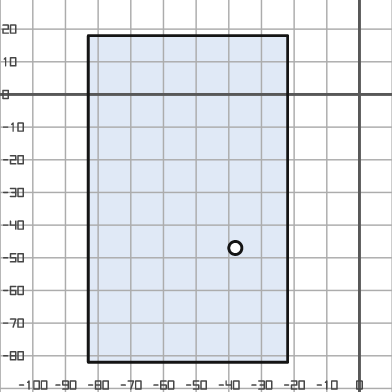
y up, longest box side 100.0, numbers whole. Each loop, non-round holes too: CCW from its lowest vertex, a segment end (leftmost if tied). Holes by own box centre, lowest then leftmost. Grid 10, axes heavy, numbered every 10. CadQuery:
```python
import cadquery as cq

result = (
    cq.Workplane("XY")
    .moveTo(-83.0, -82.0)
    .lineTo(-22.0, -82.0)
    .lineTo(-22.0, 18.0)
    .lineTo(-83.0, 18.0)
    .close()
    .moveTo(-38.0, -47.0)
    .circle(2.0)
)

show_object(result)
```